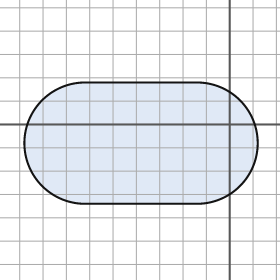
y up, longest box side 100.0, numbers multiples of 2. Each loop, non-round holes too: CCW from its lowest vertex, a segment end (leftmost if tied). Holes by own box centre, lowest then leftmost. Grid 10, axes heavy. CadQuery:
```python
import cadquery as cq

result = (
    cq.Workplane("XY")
    .moveTo(-62.0, -34.0)
    .lineTo(-14.0, -34.0)
    .threePointArc((12.0, -8.0), (-14.0, 18.0))
    .lineTo(-62.0, 18.0)
    .threePointArc((-88.0, -8.0), (-62.0, -34.0))
    .close()
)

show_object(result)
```